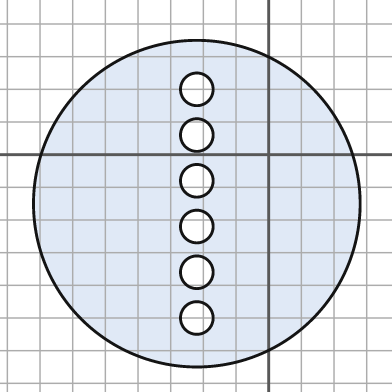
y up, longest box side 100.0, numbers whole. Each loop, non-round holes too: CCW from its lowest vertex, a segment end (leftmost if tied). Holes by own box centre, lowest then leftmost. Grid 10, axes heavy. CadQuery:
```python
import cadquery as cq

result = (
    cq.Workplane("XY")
    .moveTo(-22.0, -15.0)
    .circle(50.0)
    .moveTo(-22.0, -50.0)
    .circle(5.0)
    .moveTo(-22.0, -36.0)
    .circle(5.0)
    .moveTo(-22.0, -22.0)
    .circle(5.0)
    .moveTo(-22.0, -8.0)
    .circle(5.0)
    .moveTo(-22.0, 6.0)
    .circle(5.0)
    .moveTo(-22.0, 20.0)
    .circle(5.0)
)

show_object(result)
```